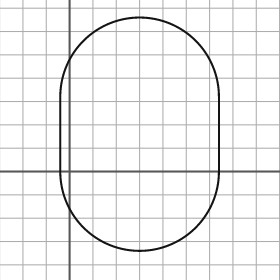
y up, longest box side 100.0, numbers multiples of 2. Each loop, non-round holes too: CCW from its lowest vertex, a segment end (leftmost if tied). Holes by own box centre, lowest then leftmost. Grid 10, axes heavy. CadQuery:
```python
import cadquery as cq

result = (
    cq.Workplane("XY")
    .moveTo(-4.0, 0.0)
    .threePointArc((30.0, -34.0), (64.0, 0.0))
    .lineTo(64.0, 32.0)
    .threePointArc((30.0, 66.0), (-4.0, 32.0))
    .close()
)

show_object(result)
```